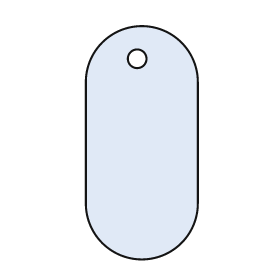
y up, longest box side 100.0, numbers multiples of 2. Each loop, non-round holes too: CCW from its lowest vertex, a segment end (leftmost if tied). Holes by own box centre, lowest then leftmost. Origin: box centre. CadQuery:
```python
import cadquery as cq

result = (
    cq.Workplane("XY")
    .moveTo(-24.0, -26.0)
    .threePointArc((0.0, -50.0), (24.0, -26.0))
    .lineTo(24.0, 26.0)
    .threePointArc((0.0, 50.0), (-24.0, 26.0))
    .close()
    .moveTo(-2.0, 36.0)
    .circle(4.0)
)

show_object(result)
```